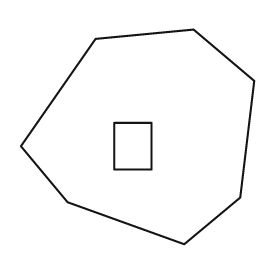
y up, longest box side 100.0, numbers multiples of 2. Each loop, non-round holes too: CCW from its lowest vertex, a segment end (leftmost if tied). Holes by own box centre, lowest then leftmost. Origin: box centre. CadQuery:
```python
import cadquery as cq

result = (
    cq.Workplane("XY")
    .moveTo(20.0, -46.0)
    .lineTo(44.0, -26.0)
    .lineTo(50.0, 24.0)
    .lineTo(24.0, 46.0)
    .lineTo(-18.0, 42.0)
    .lineTo(-50.0, -4.0)
    .lineTo(-30.0, -28.0)
    .close()
    .moveTo(-10.0, -14.0)
    .lineTo(6.0, -14.0)
    .lineTo(6.0, 6.0)
    .lineTo(-10.0, 6.0)
    .close()
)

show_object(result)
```